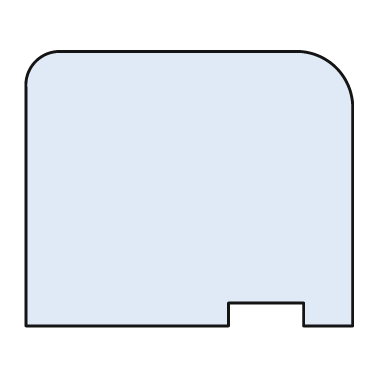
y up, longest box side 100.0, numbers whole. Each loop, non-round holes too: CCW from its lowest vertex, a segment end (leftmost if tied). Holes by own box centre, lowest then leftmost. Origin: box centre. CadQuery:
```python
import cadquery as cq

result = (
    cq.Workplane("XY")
    .moveTo(-50.0, -42.0)
    .lineTo(12.0, -42.0)
    .lineTo(12.0, -35.0)
    .lineTo(35.0, -35.0)
    .lineTo(35.0, -42.0)
    .lineTo(50.0, -42.0)
    .lineTo(50.0, 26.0)
    .threePointArc((45.0, 37.0), (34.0, 42.0))
    .lineTo(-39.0, 42.0)
    .threePointArc((-47.0, 39.0), (-50.0, 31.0))
    .close()
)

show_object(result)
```